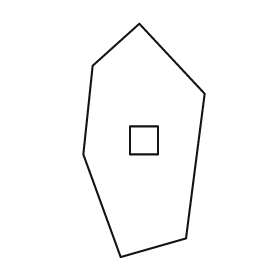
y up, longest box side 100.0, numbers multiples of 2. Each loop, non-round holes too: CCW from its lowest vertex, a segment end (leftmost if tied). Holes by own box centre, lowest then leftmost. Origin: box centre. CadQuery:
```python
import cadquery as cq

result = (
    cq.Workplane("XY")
    .moveTo(-10.0, -50.0)
    .lineTo(18.0, -42.0)
    .lineTo(26.0, 20.0)
    .lineTo(-2.0, 50.0)
    .lineTo(-22.0, 32.0)
    .lineTo(-26.0, -6.0)
    .close()
    .moveTo(-6.0, -6.0)
    .lineTo(6.0, -6.0)
    .lineTo(6.0, 6.0)
    .lineTo(-6.0, 6.0)
    .close()
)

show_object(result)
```